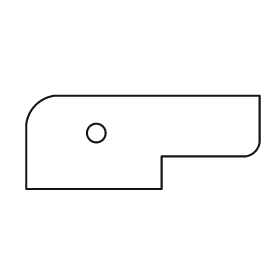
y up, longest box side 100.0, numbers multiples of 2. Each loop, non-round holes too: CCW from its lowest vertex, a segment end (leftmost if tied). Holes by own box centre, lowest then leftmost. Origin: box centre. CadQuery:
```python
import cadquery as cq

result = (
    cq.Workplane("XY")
    .moveTo(-50.0, -20.0)
    .lineTo(8.0, -20.0)
    .lineTo(8.0, -6.0)
    .lineTo(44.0, -6.0)
    .threePointArc((48.0, -4.0), (50.0, 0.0))
    .lineTo(50.0, 20.0)
    .lineTo(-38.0, 20.0)
    .threePointArc((-46.0, 16.0), (-50.0, 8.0))
    .close()
    .moveTo(-20.0, 4.0)
    .circle(4.0)
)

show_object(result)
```